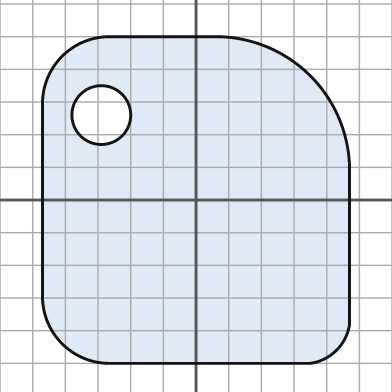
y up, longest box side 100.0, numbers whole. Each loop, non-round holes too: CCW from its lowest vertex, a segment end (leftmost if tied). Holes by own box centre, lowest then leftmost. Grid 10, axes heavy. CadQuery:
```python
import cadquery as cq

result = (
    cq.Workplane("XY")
    .moveTo(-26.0, -50.0)
    .lineTo(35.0, -50.0)
    .threePointArc((43.0, -46.0), (47.0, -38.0))
    .lineTo(47.0, 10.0)
    .threePointArc((35.0, 38.0), (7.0, 50.0))
    .lineTo(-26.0, 50.0)
    .threePointArc((-41.0, 44.0), (-47.0, 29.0))
    .lineTo(-47.0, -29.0)
    .threePointArc((-41.0, -44.0), (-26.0, -50.0))
    .close()
    .moveTo(-29.0, 26.0)
    .circle(9.0)
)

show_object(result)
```